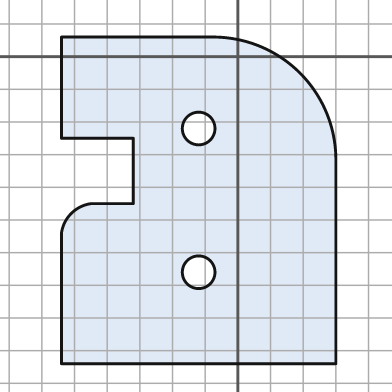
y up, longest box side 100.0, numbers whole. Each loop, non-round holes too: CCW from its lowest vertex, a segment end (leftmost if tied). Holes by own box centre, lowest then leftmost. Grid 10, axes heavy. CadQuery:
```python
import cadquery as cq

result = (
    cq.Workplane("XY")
    .moveTo(-54.0, -94.0)
    .lineTo(30.0, -94.0)
    .lineTo(30.0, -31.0)
    .threePointArc((19.0, -5.0), (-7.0, 6.0))
    .lineTo(-54.0, 6.0)
    .lineTo(-54.0, -25.0)
    .lineTo(-32.0, -25.0)
    .lineTo(-32.0, -45.0)
    .lineTo(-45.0, -45.0)
    .threePointArc((-51.0, -48.0), (-54.0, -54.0))
    .close()
    .moveTo(-12.0, -66.0)
    .circle(5.0)
    .moveTo(-12.0, -22.0)
    .circle(5.0)
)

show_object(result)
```